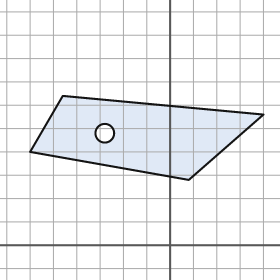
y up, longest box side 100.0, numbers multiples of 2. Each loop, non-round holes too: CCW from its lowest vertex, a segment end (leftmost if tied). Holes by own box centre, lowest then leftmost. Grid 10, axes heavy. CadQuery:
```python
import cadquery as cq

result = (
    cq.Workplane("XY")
    .moveTo(8.0, 28.0)
    .lineTo(40.0, 56.0)
    .lineTo(-46.0, 64.0)
    .lineTo(-60.0, 40.0)
    .close()
    .moveTo(-28.0, 48.0)
    .circle(4.0)
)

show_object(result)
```